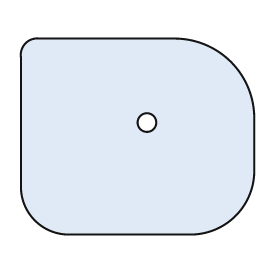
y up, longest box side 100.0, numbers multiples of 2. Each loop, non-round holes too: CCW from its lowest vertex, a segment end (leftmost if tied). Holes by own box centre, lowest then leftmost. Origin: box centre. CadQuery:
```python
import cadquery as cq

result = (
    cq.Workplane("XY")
    .moveTo(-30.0, -42.0)
    .lineTo(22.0, -42.0)
    .threePointArc((42.0, -34.0), (50.0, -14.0))
    .lineTo(50.0, 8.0)
    .threePointArc((40.0, 32.0), (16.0, 42.0))
    .lineTo(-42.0, 42.0)
    .threePointArc((-48.0, 40.0), (-50.0, 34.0))
    .lineTo(-50.0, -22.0)
    .threePointArc((-44.0, -36.0), (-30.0, -42.0))
    .close()
    .moveTo(4.0, 6.0)
    .circle(4.0)
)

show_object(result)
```